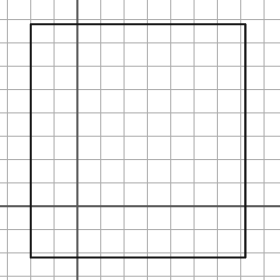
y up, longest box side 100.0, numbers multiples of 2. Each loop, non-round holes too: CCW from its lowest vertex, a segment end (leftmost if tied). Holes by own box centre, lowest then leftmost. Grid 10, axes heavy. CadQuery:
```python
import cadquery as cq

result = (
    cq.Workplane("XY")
    .moveTo(-20.0, -22.0)
    .lineTo(72.0, -22.0)
    .lineTo(72.0, 78.0)
    .lineTo(-20.0, 78.0)
    .close()
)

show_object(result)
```